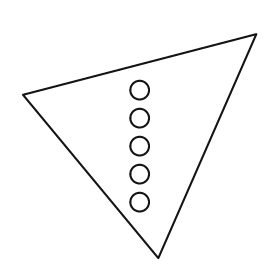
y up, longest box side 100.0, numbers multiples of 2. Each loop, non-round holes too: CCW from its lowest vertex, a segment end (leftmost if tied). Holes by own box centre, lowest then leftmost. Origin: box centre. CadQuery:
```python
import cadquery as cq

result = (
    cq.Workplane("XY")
    .moveTo(8.0, -48.0)
    .lineTo(50.0, 48.0)
    .lineTo(-50.0, 22.0)
    .close()
    .moveTo(0.0, -24.0)
    .circle(4.0)
    .moveTo(0.0, -12.0)
    .circle(4.0)
    .moveTo(0.0, 0.0)
    .circle(4.0)
    .moveTo(0.0, 12.0)
    .circle(4.0)
    .moveTo(0.0, 24.0)
    .circle(4.0)
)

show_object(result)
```